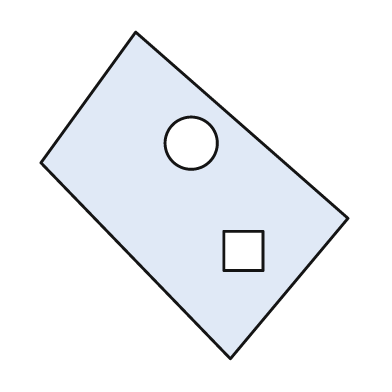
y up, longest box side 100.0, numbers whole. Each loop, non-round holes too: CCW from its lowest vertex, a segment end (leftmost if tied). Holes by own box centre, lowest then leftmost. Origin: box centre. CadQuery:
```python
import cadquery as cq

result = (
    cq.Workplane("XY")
    .moveTo(11.0, -50.0)
    .lineTo(47.0, -7.0)
    .lineTo(-18.0, 50.0)
    .lineTo(-47.0, 10.0)
    .close()
    .moveTo(9.0, -23.0)
    .lineTo(21.0, -23.0)
    .lineTo(21.0, -11.0)
    .lineTo(9.0, -11.0)
    .close()
    .moveTo(-1.0, 16.0)
    .circle(8.0)
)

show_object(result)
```